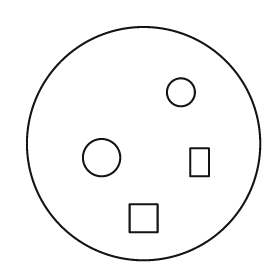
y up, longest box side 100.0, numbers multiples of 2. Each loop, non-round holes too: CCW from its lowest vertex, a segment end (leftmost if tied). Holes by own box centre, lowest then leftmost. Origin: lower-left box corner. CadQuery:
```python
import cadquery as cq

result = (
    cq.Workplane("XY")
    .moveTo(50.0, 50.0)
    .circle(50.0)
    .moveTo(44.0, 12.0)
    .lineTo(56.0, 12.0)
    .lineTo(56.0, 24.0)
    .lineTo(44.0, 24.0)
    .close()
    .moveTo(70.0, 36.0)
    .lineTo(78.0, 36.0)
    .lineTo(78.0, 48.0)
    .lineTo(70.0, 48.0)
    .close()
    .moveTo(32.0, 44.0)
    .circle(8.0)
    .moveTo(66.0, 72.0)
    .circle(6.0)
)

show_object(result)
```